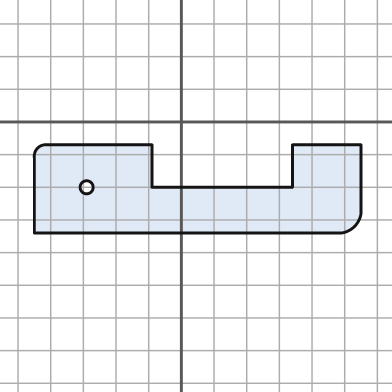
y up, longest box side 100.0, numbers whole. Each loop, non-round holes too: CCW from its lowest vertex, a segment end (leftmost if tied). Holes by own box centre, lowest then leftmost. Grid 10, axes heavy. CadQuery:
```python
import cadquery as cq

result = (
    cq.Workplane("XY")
    .moveTo(-45.0, -34.0)
    .lineTo(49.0, -34.0)
    .threePointArc((53.0, -32.0), (55.0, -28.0))
    .lineTo(55.0, -7.0)
    .lineTo(34.0, -7.0)
    .lineTo(34.0, -20.0)
    .lineTo(-9.0, -20.0)
    .lineTo(-9.0, -7.0)
    .lineTo(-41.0, -7.0)
    .threePointArc((-44.0, -8.0), (-45.0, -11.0))
    .close()
    .moveTo(-29.0, -20.0)
    .circle(2.0)
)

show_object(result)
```